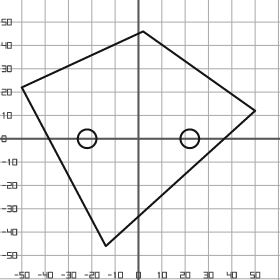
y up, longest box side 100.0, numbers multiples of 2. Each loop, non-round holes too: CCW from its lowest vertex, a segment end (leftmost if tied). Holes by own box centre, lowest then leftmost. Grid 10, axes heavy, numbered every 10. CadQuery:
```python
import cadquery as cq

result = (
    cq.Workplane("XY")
    .moveTo(-14.0, -46.0)
    .lineTo(50.0, 12.0)
    .lineTo(2.0, 46.0)
    .lineTo(-50.0, 22.0)
    .close()
    .moveTo(-22.0, 0.0)
    .circle(4.0)
    .moveTo(22.0, 0.0)
    .circle(4.0)
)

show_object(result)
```